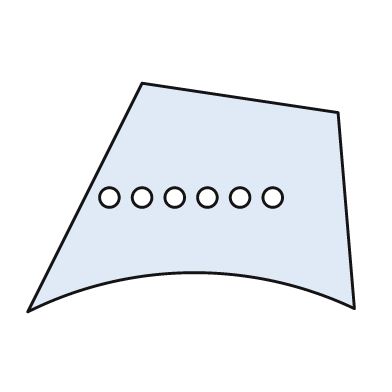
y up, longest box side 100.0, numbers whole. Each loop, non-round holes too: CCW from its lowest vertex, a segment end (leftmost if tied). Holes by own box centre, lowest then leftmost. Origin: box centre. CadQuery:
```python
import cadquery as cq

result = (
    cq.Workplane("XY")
    .moveTo(-50.0, -35.0)
    .threePointArc((0.0, -23.0), (50.0, -34.0))
    .lineTo(45.0, 26.0)
    .lineTo(-15.0, 35.0)
    .close()
    .moveTo(-25.0, 0.0)
    .circle(3.0)
    .moveTo(-15.0, 0.0)
    .circle(3.0)
    .moveTo(-5.0, 0.0)
    .circle(3.0)
    .moveTo(5.0, 0.0)
    .circle(3.0)
    .moveTo(15.0, 0.0)
    .circle(3.0)
    .moveTo(25.0, 0.0)
    .circle(3.0)
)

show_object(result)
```